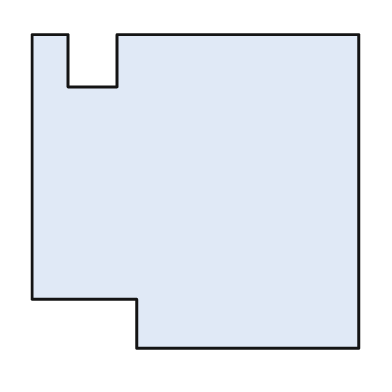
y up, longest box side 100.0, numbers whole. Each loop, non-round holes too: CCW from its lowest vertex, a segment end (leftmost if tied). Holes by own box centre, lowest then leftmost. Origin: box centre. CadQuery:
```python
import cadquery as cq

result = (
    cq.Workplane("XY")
    .moveTo(-18.0, -48.0)
    .lineTo(50.0, -48.0)
    .lineTo(50.0, 48.0)
    .lineTo(-24.0, 48.0)
    .lineTo(-24.0, 32.0)
    .lineTo(-39.0, 32.0)
    .lineTo(-39.0, 48.0)
    .lineTo(-50.0, 48.0)
    .lineTo(-50.0, -33.0)
    .lineTo(-18.0, -33.0)
    .close()
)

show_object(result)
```